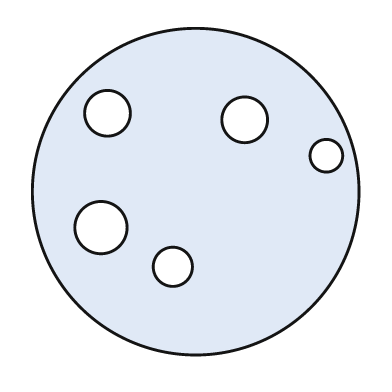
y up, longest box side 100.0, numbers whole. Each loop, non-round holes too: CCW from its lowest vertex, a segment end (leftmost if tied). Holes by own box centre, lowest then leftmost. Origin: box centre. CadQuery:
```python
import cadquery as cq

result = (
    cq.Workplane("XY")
    .moveTo(0.0, 0.0)
    .circle(50.0)
    .moveTo(-7.0, -23.0)
    .circle(6.0)
    .moveTo(-29.0, -11.0)
    .circle(8.0)
    .moveTo(40.0, 11.0)
    .circle(5.0)
    .moveTo(15.0, 22.0)
    .circle(7.0)
    .moveTo(-27.0, 24.0)
    .circle(7.0)
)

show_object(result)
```